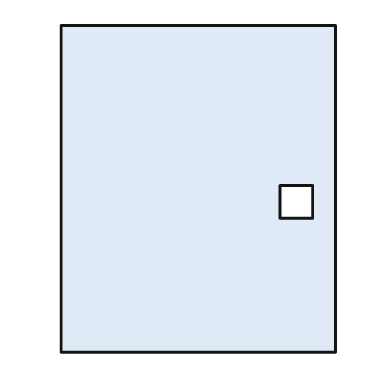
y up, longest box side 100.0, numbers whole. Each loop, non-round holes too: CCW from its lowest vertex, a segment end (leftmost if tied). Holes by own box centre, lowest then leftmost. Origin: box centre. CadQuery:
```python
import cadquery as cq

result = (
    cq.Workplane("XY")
    .moveTo(-42.0, -50.0)
    .lineTo(42.0, -50.0)
    .lineTo(42.0, 50.0)
    .lineTo(-42.0, 50.0)
    .close()
    .moveTo(25.0, -9.0)
    .lineTo(35.0, -9.0)
    .lineTo(35.0, 1.0)
    .lineTo(25.0, 1.0)
    .close()
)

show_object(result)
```